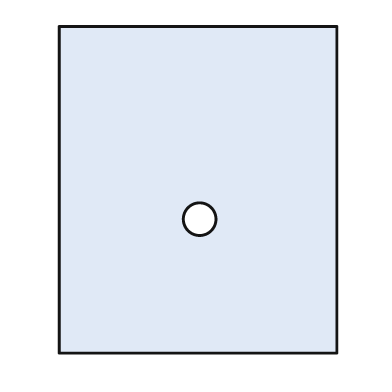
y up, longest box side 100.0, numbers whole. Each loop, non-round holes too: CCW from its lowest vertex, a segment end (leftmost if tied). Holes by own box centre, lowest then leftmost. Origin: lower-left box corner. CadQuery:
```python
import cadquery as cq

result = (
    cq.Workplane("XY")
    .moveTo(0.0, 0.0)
    .lineTo(85.0, 0.0)
    .lineTo(85.0, 100.0)
    .lineTo(0.0, 100.0)
    .close()
    .moveTo(43.0, 41.0)
    .circle(5.0)
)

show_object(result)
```